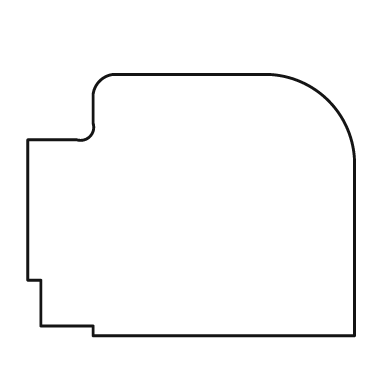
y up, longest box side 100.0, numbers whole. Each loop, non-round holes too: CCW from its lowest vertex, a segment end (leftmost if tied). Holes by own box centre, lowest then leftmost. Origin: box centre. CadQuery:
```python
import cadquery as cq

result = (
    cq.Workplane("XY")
    .moveTo(-30.0, -40.0)
    .lineTo(50.0, -40.0)
    .lineTo(50.0, 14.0)
    .threePointArc((42.0, 32.0), (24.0, 40.0))
    .lineTo(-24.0, 40.0)
    .threePointArc((-28.0, 38.0), (-30.0, 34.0))
    .lineTo(-30.0, 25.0)
    .threePointArc((-31.0, 21.0), (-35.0, 20.0))
    .lineTo(-50.0, 20.0)
    .lineTo(-50.0, -23.0)
    .lineTo(-46.0, -23.0)
    .lineTo(-46.0, -37.0)
    .lineTo(-30.0, -37.0)
    .close()
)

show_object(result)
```